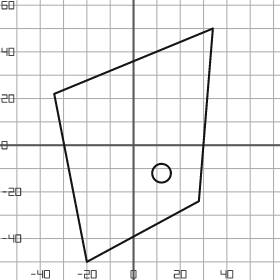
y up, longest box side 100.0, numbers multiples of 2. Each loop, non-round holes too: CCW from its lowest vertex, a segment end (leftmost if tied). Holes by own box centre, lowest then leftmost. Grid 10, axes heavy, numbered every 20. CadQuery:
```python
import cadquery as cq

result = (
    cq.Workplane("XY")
    .moveTo(-20.0, -50.0)
    .lineTo(28.0, -24.0)
    .lineTo(34.0, 50.0)
    .lineTo(-34.0, 22.0)
    .close()
    .moveTo(12.0, -12.0)
    .circle(4.0)
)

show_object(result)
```